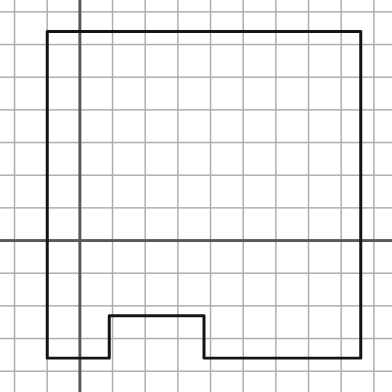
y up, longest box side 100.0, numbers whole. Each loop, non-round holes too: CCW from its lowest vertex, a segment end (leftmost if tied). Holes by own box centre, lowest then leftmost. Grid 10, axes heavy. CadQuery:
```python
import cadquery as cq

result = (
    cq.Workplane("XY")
    .moveTo(-10.0, -36.0)
    .lineTo(9.0, -36.0)
    .lineTo(9.0, -23.0)
    .lineTo(38.0, -23.0)
    .lineTo(38.0, -36.0)
    .lineTo(86.0, -36.0)
    .lineTo(86.0, 64.0)
    .lineTo(-10.0, 64.0)
    .close()
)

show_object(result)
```